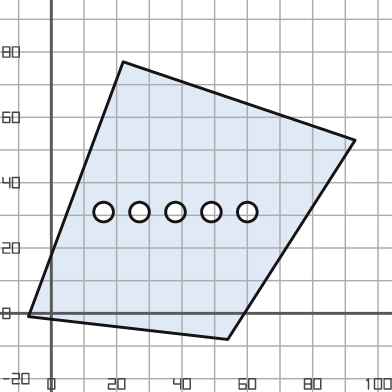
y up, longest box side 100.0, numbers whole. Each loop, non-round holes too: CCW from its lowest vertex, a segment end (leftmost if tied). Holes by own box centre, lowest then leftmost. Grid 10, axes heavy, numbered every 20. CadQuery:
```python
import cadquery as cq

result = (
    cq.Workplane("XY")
    .moveTo(54.0, -8.0)
    .lineTo(93.0, 53.0)
    .lineTo(22.0, 77.0)
    .lineTo(-7.0, -1.0)
    .close()
    .moveTo(16.0, 31.0)
    .circle(3.0)
    .moveTo(27.0, 31.0)
    .circle(3.0)
    .moveTo(38.0, 31.0)
    .circle(3.0)
    .moveTo(49.0, 31.0)
    .circle(3.0)
    .moveTo(60.0, 31.0)
    .circle(3.0)
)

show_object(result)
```